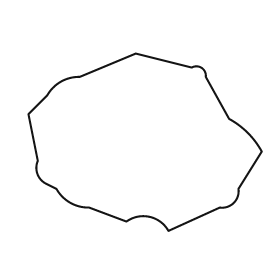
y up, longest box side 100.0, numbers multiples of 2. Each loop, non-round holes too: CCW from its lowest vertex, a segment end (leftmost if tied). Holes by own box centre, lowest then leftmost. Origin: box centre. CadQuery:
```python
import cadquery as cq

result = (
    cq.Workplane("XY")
    .moveTo(10.0, -38.0)
    .lineTo(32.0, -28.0)
    .threePointArc((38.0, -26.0), (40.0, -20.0))
    .lineTo(50.0, -4.0)
    .threePointArc((44.0, 4.0), (36.0, 10.0))
    .lineTo(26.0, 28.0)
    .threePointArc((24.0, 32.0), (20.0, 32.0))
    .lineTo(-4.0, 38.0)
    .lineTo(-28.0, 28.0)
    .threePointArc((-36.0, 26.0), (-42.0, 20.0))
    .lineTo(-50.0, 12.0)
    .lineTo(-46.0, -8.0)
    .threePointArc((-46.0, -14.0), (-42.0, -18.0))
    .lineTo(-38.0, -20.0)
    .threePointArc((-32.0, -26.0), (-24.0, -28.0))
    .lineTo(-8.0, -34.0)
    .threePointArc((2.0, -32.0), (10.0, -38.0))
    .close()
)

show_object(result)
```